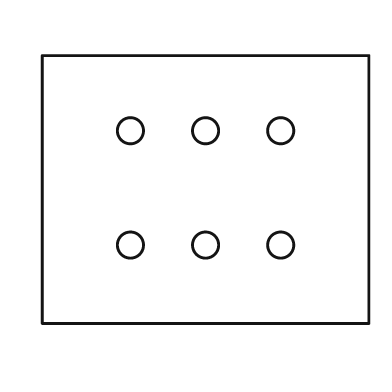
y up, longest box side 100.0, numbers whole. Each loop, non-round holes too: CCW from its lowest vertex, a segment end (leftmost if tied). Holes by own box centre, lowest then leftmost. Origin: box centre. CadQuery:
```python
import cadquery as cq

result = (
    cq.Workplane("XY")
    .moveTo(-50.0, -41.0)
    .lineTo(50.0, -41.0)
    .lineTo(50.0, 41.0)
    .lineTo(-50.0, 41.0)
    .close()
    .moveTo(-23.0, -17.0)
    .circle(4.0)
    .moveTo(0.0, -17.0)
    .circle(4.0)
    .moveTo(23.0, -17.0)
    .circle(4.0)
    .moveTo(-23.0, 18.0)
    .circle(4.0)
    .moveTo(0.0, 18.0)
    .circle(4.0)
    .moveTo(23.0, 18.0)
    .circle(4.0)
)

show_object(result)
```